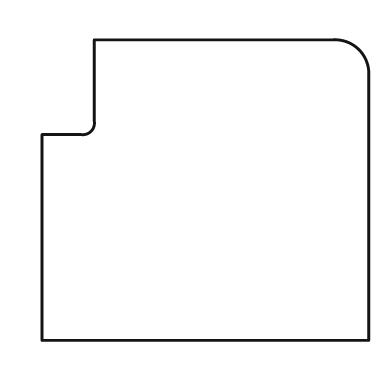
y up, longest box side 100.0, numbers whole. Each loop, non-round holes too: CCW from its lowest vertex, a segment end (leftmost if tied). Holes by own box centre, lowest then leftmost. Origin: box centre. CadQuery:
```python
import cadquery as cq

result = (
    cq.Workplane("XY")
    .moveTo(-50.0, -46.0)
    .lineTo(50.0, -46.0)
    .lineTo(50.0, 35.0)
    .threePointArc((47.0, 43.0), (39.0, 46.0))
    .lineTo(-34.0, 46.0)
    .lineTo(-34.0, 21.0)
    .threePointArc((-35.0, 18.0), (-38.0, 17.0))
    .lineTo(-50.0, 17.0)
    .close()
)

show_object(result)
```